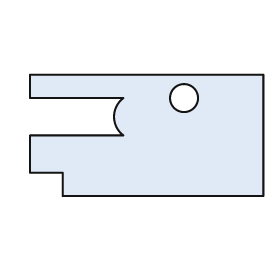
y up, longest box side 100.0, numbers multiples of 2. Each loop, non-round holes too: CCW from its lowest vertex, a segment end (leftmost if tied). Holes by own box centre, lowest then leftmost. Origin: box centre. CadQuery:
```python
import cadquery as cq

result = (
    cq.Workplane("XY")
    .moveTo(-36.0, -26.0)
    .lineTo(50.0, -26.0)
    .lineTo(50.0, 26.0)
    .lineTo(-50.0, 26.0)
    .lineTo(-50.0, 16.0)
    .lineTo(-10.0, 16.0)
    .threePointArc((-14.0, 8.0), (-10.0, 0.0))
    .lineTo(-50.0, 0.0)
    .lineTo(-50.0, -16.0)
    .lineTo(-36.0, -16.0)
    .close()
    .moveTo(16.0, 16.0)
    .circle(6.0)
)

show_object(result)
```